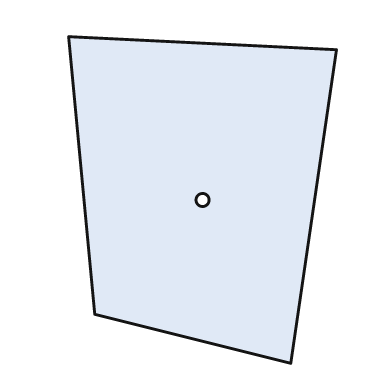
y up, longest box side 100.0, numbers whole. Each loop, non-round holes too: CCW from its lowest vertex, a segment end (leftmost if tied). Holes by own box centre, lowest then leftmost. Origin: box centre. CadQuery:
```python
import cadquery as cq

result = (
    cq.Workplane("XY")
    .moveTo(27.0, -50.0)
    .lineTo(41.0, 46.0)
    .lineTo(-41.0, 50.0)
    .lineTo(-33.0, -35.0)
    .close()
    .moveTo(0.0, 0.0)
    .circle(2.0)
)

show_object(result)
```